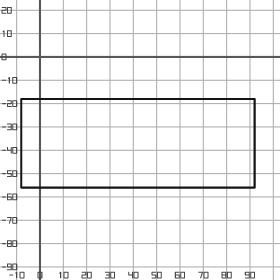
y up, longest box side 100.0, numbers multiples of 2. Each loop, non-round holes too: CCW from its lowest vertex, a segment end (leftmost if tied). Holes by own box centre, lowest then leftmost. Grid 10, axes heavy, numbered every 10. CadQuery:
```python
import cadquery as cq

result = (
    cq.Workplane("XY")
    .moveTo(-8.0, -56.0)
    .lineTo(92.0, -56.0)
    .lineTo(92.0, -18.0)
    .lineTo(-8.0, -18.0)
    .close()
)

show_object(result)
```